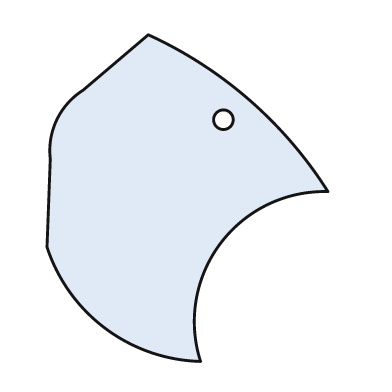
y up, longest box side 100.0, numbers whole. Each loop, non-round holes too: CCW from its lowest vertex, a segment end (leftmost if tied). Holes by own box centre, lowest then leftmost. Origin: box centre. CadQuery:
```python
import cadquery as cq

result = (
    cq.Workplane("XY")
    .moveTo(4.0, -50.0)
    .threePointArc((10.0, -14.0), (43.0, 2.0))
    .threePointArc((19.0, 30.0), (-12.0, 50.0))
    .lineTo(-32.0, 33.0)
    .threePointArc((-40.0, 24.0), (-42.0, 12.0))
    .lineTo(-43.0, -15.0)
    .threePointArc((-25.0, -40.0), (4.0, -50.0))
    .close()
    .moveTo(11.0, 24.0)
    .circle(3.0)
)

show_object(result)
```